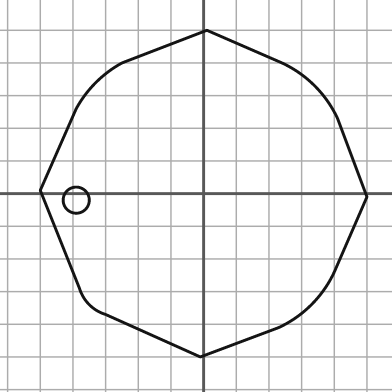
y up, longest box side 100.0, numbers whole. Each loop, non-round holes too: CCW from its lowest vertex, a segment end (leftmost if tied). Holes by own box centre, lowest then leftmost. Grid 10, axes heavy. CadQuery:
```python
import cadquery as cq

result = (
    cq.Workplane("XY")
    .moveTo(-1.0, -50.0)
    .lineTo(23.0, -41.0)
    .threePointArc((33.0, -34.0), (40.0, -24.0))
    .lineTo(50.0, -1.0)
    .lineTo(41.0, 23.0)
    .threePointArc((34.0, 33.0), (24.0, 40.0))
    .lineTo(1.0, 50.0)
    .lineTo(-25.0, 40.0)
    .threePointArc((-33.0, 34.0), (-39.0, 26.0))
    .lineTo(-50.0, 1.0)
    .lineTo(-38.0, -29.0)
    .threePointArc((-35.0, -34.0), (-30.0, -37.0))
    .close()
    .moveTo(-39.0, -2.0)
    .circle(4.0)
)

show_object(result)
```